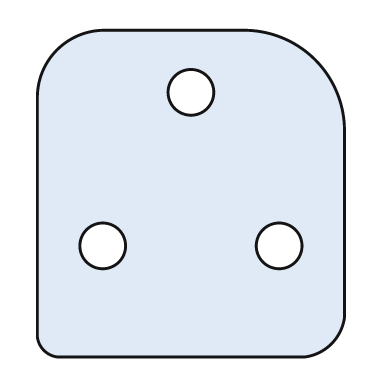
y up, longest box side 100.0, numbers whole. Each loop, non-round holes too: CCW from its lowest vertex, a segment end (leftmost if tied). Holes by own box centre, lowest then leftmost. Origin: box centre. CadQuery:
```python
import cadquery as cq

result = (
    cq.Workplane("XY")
    .moveTo(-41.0, -50.0)
    .lineTo(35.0, -50.0)
    .threePointArc((43.0, -46.0), (47.0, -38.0))
    .lineTo(47.0, 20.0)
    .threePointArc((38.0, 41.0), (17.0, 50.0))
    .lineTo(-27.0, 50.0)
    .threePointArc((-41.0, 44.0), (-47.0, 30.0))
    .lineTo(-47.0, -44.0)
    .threePointArc((-45.0, -48.0), (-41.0, -50.0))
    .close()
    .moveTo(-27.0, -16.0)
    .circle(7.0)
    .moveTo(27.0, -16.0)
    .circle(7.0)
    .moveTo(0.0, 31.0)
    .circle(7.0)
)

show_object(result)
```